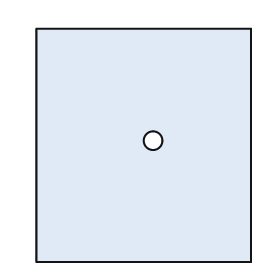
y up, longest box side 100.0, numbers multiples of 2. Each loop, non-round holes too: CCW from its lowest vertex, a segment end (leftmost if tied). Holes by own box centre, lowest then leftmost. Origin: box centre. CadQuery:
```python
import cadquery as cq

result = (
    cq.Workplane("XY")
    .moveTo(-46.0, -50.0)
    .lineTo(46.0, -50.0)
    .lineTo(46.0, 50.0)
    .lineTo(-46.0, 50.0)
    .close()
    .moveTo(4.0, 2.0)
    .circle(4.0)
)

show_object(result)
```